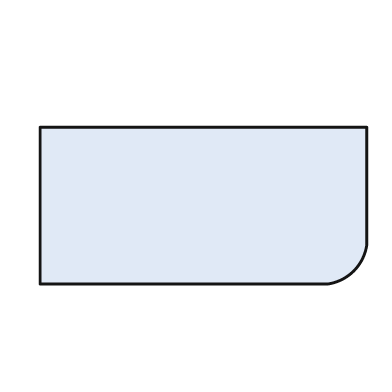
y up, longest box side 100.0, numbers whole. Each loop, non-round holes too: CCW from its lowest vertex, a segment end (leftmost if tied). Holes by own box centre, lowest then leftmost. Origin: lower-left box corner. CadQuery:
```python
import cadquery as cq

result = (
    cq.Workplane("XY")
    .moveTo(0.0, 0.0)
    .lineTo(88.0, 0.0)
    .threePointArc((96.0, 4.0), (100.0, 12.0))
    .lineTo(100.0, 48.0)
    .lineTo(0.0, 48.0)
    .close()
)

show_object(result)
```